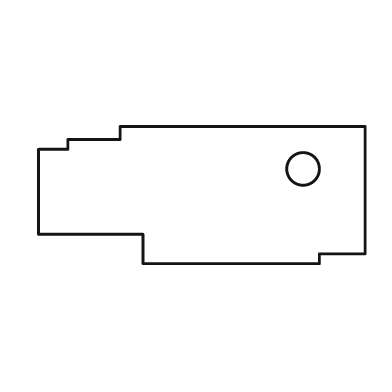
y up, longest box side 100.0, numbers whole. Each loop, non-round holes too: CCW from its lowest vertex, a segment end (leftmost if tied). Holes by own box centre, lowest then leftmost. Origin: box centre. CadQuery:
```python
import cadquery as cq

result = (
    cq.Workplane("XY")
    .moveTo(-18.0, -21.0)
    .lineTo(36.0, -21.0)
    .lineTo(36.0, -18.0)
    .lineTo(50.0, -18.0)
    .lineTo(50.0, 21.0)
    .lineTo(-25.0, 21.0)
    .lineTo(-25.0, 17.0)
    .lineTo(-41.0, 17.0)
    .lineTo(-41.0, 14.0)
    .lineTo(-50.0, 14.0)
    .lineTo(-50.0, -12.0)
    .lineTo(-18.0, -12.0)
    .close()
    .moveTo(31.0, 8.0)
    .circle(5.0)
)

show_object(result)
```